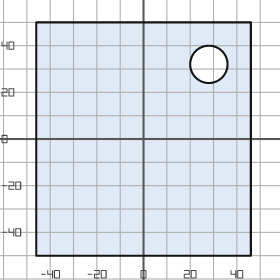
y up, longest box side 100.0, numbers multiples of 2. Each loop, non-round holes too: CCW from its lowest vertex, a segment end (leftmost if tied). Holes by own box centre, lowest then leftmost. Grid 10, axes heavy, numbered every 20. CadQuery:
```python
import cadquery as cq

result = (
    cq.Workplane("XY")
    .moveTo(-46.0, -50.0)
    .lineTo(46.0, -50.0)
    .lineTo(46.0, 50.0)
    .lineTo(-46.0, 50.0)
    .close()
    .moveTo(28.0, 32.0)
    .circle(8.0)
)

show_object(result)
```